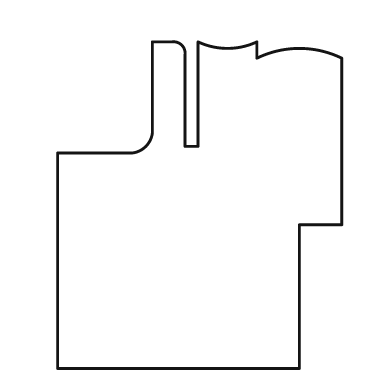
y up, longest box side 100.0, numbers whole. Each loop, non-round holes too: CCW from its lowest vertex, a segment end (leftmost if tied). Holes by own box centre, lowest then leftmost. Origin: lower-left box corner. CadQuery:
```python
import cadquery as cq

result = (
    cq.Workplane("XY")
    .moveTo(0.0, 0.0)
    .lineTo(74.0, 0.0)
    .lineTo(74.0, 44.0)
    .lineTo(87.0, 44.0)
    .lineTo(87.0, 95.0)
    .threePointArc((74.0, 98.0), (61.0, 95.0))
    .lineTo(61.0, 100.0)
    .threePointArc((52.0, 98.0), (43.0, 100.0))
    .lineTo(43.0, 68.0)
    .lineTo(39.0, 68.0)
    .lineTo(39.0, 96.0)
    .threePointArc((38.0, 99.0), (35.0, 100.0))
    .lineTo(29.0, 100.0)
    .lineTo(29.0, 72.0)
    .threePointArc((27.0, 68.0), (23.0, 66.0))
    .lineTo(0.0, 66.0)
    .close()
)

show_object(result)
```